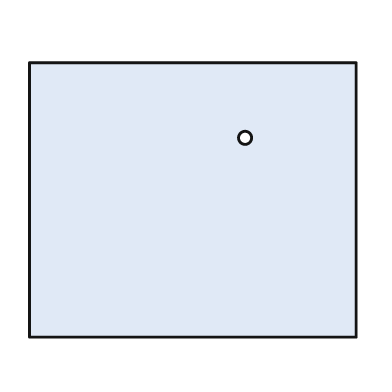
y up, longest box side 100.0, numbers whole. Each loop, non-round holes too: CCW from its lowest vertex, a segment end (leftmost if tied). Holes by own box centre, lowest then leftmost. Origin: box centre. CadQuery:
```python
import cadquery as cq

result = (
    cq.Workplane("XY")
    .moveTo(-50.0, -42.0)
    .lineTo(50.0, -42.0)
    .lineTo(50.0, 42.0)
    .lineTo(-50.0, 42.0)
    .close()
    .moveTo(16.0, 19.0)
    .circle(2.0)
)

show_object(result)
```